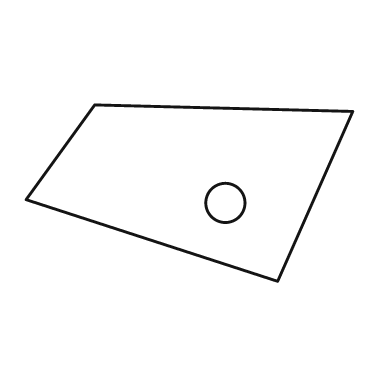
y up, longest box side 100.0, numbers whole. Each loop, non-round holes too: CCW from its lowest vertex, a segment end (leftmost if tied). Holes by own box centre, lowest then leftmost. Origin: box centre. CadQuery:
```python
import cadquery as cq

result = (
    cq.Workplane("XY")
    .moveTo(27.0, -27.0)
    .lineTo(50.0, 25.0)
    .lineTo(-29.0, 27.0)
    .lineTo(-50.0, -2.0)
    .close()
    .moveTo(11.0, -3.0)
    .circle(6.0)
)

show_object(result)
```